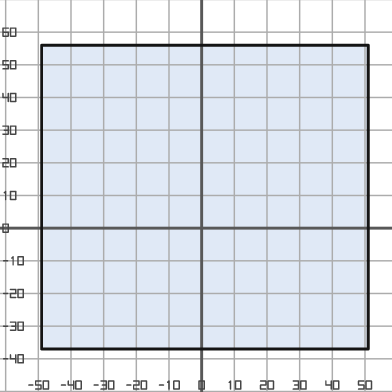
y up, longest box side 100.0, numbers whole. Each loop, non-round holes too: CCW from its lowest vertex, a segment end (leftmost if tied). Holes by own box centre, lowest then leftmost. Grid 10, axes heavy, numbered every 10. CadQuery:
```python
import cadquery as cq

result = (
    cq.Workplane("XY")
    .moveTo(-49.0, -37.0)
    .lineTo(51.0, -37.0)
    .lineTo(51.0, 56.0)
    .lineTo(-49.0, 56.0)
    .close()
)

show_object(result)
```